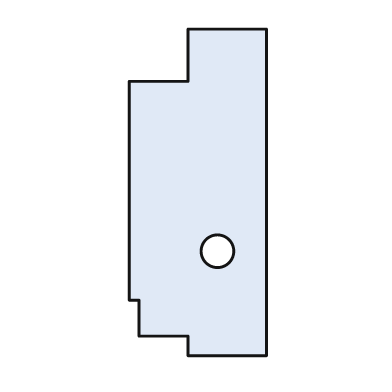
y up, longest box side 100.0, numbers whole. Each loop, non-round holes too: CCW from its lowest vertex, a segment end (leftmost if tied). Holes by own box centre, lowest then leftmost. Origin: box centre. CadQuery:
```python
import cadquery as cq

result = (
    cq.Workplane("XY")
    .moveTo(-3.0, -50.0)
    .lineTo(21.0, -50.0)
    .lineTo(21.0, 50.0)
    .lineTo(-3.0, 50.0)
    .lineTo(-3.0, 34.0)
    .lineTo(-21.0, 34.0)
    .lineTo(-21.0, -33.0)
    .lineTo(-18.0, -33.0)
    .lineTo(-18.0, -44.0)
    .lineTo(-3.0, -44.0)
    .close()
    .moveTo(6.0, -18.0)
    .circle(5.0)
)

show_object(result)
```